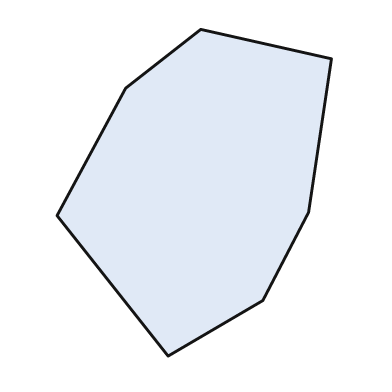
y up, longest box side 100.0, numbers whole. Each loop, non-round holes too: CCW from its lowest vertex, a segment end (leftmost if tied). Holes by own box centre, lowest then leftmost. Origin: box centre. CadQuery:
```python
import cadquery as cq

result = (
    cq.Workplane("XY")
    .moveTo(-8.0, -50.0)
    .lineTo(21.0, -33.0)
    .lineTo(35.0, -6.0)
    .lineTo(42.0, 41.0)
    .lineTo(2.0, 50.0)
    .lineTo(-21.0, 32.0)
    .lineTo(-42.0, -7.0)
    .close()
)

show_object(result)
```